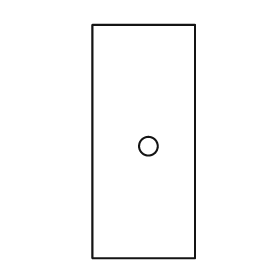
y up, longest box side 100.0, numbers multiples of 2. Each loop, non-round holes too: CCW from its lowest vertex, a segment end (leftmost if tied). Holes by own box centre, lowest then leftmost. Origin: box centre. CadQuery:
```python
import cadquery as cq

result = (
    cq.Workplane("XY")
    .moveTo(-22.0, -50.0)
    .lineTo(22.0, -50.0)
    .lineTo(22.0, 50.0)
    .lineTo(-22.0, 50.0)
    .close()
    .moveTo(2.0, -2.0)
    .circle(4.0)
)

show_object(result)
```